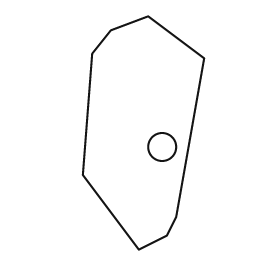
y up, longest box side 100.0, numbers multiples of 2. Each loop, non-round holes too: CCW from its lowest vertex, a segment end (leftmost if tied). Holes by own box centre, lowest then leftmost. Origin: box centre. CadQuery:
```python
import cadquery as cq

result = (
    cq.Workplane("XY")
    .moveTo(-2.0, -50.0)
    .lineTo(10.0, -44.0)
    .lineTo(14.0, -36.0)
    .lineTo(26.0, 32.0)
    .lineTo(2.0, 50.0)
    .lineTo(-14.0, 44.0)
    .lineTo(-22.0, 34.0)
    .lineTo(-26.0, -18.0)
    .close()
    .moveTo(8.0, -6.0)
    .circle(6.0)
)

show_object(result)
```